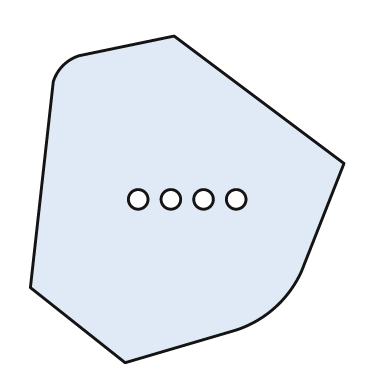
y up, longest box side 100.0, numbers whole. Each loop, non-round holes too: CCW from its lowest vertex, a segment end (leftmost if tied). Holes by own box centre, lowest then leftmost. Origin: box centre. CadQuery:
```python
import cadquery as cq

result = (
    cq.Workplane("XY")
    .moveTo(-19.0, -50.0)
    .lineTo(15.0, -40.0)
    .threePointArc((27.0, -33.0), (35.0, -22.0))
    .lineTo(48.0, 11.0)
    .lineTo(-4.0, 50.0)
    .lineTo(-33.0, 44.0)
    .threePointArc((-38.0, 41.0), (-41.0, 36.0))
    .lineTo(-48.0, -27.0)
    .close()
    .moveTo(-15.0, 0.0)
    .circle(3.0)
    .moveTo(-5.0, 0.0)
    .circle(3.0)
    .moveTo(5.0, 0.0)
    .circle(3.0)
    .moveTo(15.0, 0.0)
    .circle(3.0)
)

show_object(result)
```